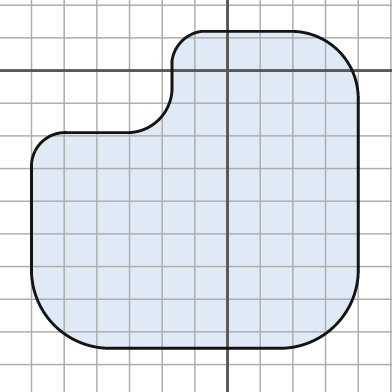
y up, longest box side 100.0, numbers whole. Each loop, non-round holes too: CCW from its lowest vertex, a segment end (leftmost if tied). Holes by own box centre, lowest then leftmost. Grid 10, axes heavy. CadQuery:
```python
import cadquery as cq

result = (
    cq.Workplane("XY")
    .moveTo(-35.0, -85.0)
    .lineTo(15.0, -85.0)
    .threePointArc((33.0, -78.0), (40.0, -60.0))
    .lineTo(40.0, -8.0)
    .threePointArc((34.0, 6.0), (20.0, 12.0))
    .lineTo(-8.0, 12.0)
    .threePointArc((-14.0, 9.0), (-17.0, 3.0))
    .lineTo(-17.0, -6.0)
    .threePointArc((-21.0, -15.0), (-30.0, -19.0))
    .lineTo(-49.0, -19.0)
    .threePointArc((-57.0, -22.0), (-60.0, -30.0))
    .lineTo(-60.0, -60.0)
    .threePointArc((-53.0, -78.0), (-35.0, -85.0))
    .close()
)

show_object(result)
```